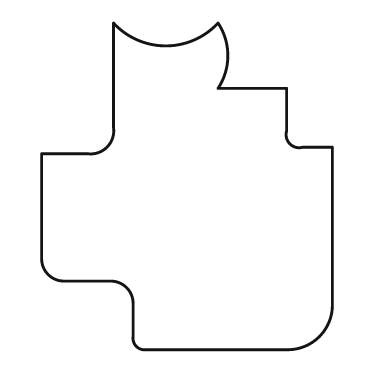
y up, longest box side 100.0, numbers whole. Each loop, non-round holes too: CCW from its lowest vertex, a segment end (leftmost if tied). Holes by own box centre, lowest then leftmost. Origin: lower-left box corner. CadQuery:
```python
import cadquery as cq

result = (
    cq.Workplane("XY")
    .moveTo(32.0, 0.0)
    .lineTo(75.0, 0.0)
    .threePointArc((85.0, 4.0), (89.0, 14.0))
    .lineTo(89.0, 62.0)
    .lineTo(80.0, 62.0)
    .threePointArc((76.0, 63.0), (75.0, 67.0))
    .lineTo(75.0, 80.0)
    .lineTo(54.0, 80.0)
    .threePointArc((57.0, 90.0), (54.0, 100.0))
    .threePointArc((38.0, 93.0), (22.0, 100.0))
    .lineTo(22.0, 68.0)
    .threePointArc((20.0, 62.0), (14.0, 60.0))
    .lineTo(0.0, 60.0)
    .lineTo(0.0, 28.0)
    .threePointArc((2.0, 23.0), (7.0, 21.0))
    .lineTo(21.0, 21.0)
    .threePointArc((26.0, 19.0), (28.0, 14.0))
    .lineTo(28.0, 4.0)
    .threePointArc((29.0, 1.0), (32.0, 0.0))
    .close()
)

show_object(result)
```